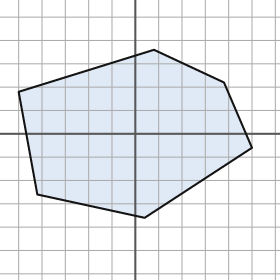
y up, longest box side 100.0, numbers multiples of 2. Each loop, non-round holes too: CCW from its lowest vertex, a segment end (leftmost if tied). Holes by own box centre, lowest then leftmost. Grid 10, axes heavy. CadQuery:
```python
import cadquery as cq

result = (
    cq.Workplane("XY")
    .moveTo(4.0, -36.0)
    .lineTo(50.0, -6.0)
    .lineTo(38.0, 22.0)
    .lineTo(8.0, 36.0)
    .lineTo(-50.0, 18.0)
    .lineTo(-42.0, -26.0)
    .close()
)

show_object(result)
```